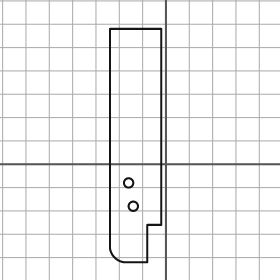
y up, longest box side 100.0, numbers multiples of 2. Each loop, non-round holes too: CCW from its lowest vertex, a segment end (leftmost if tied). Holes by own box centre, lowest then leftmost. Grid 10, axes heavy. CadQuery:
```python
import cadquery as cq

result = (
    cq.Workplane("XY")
    .moveTo(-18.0, -42.0)
    .lineTo(-8.0, -42.0)
    .lineTo(-8.0, -26.0)
    .lineTo(-2.0, -26.0)
    .lineTo(-2.0, 58.0)
    .lineTo(-24.0, 58.0)
    .lineTo(-24.0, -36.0)
    .threePointArc((-22.0, -40.0), (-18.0, -42.0))
    .close()
    .moveTo(-14.0, -18.0)
    .circle(2.0)
    .moveTo(-16.0, -8.0)
    .circle(2.0)
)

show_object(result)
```